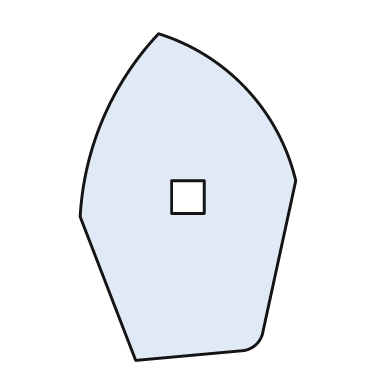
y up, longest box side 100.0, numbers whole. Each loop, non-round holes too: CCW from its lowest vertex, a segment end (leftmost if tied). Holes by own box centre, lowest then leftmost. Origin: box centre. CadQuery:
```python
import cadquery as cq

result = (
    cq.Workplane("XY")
    .moveTo(-16.0, -50.0)
    .lineTo(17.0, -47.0)
    .threePointArc((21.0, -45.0), (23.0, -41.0))
    .lineTo(33.0, 5.0)
    .threePointArc((18.0, 33.0), (-9.0, 50.0))
    .threePointArc((-26.0, 24.0), (-33.0, -6.0))
    .close()
    .moveTo(-5.0, -5.0)
    .lineTo(5.0, -5.0)
    .lineTo(5.0, 5.0)
    .lineTo(-5.0, 5.0)
    .close()
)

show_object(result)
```